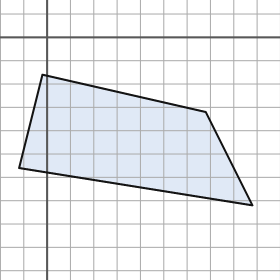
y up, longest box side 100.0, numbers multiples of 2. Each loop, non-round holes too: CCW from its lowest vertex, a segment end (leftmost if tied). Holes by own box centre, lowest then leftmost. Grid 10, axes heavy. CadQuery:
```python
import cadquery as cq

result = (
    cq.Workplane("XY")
    .moveTo(88.0, -72.0)
    .lineTo(68.0, -32.0)
    .lineTo(-2.0, -16.0)
    .lineTo(-12.0, -56.0)
    .close()
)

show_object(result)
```